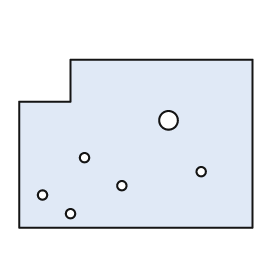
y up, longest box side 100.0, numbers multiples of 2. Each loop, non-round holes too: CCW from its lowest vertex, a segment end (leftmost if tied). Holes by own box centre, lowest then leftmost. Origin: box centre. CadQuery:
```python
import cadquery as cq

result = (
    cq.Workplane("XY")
    .moveTo(-50.0, -36.0)
    .lineTo(50.0, -36.0)
    .lineTo(50.0, 36.0)
    .lineTo(-28.0, 36.0)
    .lineTo(-28.0, 18.0)
    .lineTo(-50.0, 18.0)
    .close()
    .moveTo(-28.0, -30.0)
    .circle(2.0)
    .moveTo(-40.0, -22.0)
    .circle(2.0)
    .moveTo(-6.0, -18.0)
    .circle(2.0)
    .moveTo(28.0, -12.0)
    .circle(2.0)
    .moveTo(-22.0, -6.0)
    .circle(2.0)
    .moveTo(14.0, 10.0)
    .circle(4.0)
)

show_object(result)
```